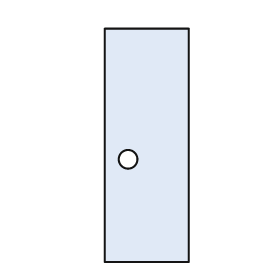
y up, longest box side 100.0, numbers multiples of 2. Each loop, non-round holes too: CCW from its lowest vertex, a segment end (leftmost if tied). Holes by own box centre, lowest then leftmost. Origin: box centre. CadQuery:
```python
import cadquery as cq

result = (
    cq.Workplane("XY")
    .moveTo(-18.0, -50.0)
    .lineTo(18.0, -50.0)
    .lineTo(18.0, 50.0)
    .lineTo(-18.0, 50.0)
    .close()
    .moveTo(-8.0, -6.0)
    .circle(4.0)
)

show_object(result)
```